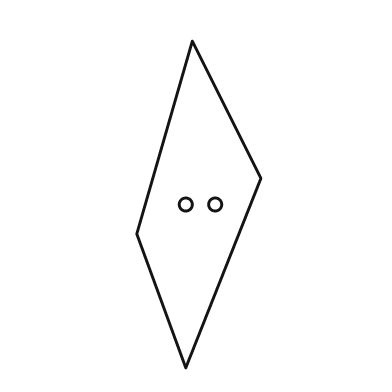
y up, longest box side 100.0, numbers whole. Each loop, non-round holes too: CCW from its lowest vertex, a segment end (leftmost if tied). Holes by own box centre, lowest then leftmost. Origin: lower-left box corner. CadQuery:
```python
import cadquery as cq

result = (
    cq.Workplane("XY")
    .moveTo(15.0, 0.0)
    .lineTo(38.0, 58.0)
    .lineTo(17.0, 100.0)
    .lineTo(0.0, 41.0)
    .close()
    .moveTo(15.0, 50.0)
    .circle(2.0)
    .moveTo(24.0, 50.0)
    .circle(2.0)
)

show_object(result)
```